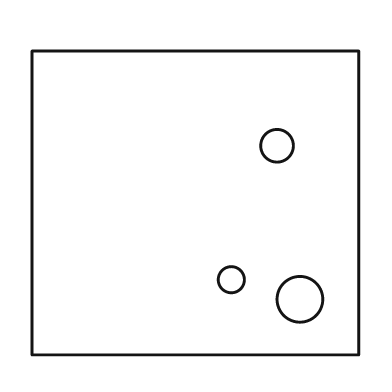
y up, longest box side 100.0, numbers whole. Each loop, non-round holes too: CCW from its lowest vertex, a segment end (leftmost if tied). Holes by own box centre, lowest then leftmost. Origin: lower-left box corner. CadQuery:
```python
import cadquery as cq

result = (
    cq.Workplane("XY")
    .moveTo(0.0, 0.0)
    .lineTo(100.0, 0.0)
    .lineTo(100.0, 93.0)
    .lineTo(0.0, 93.0)
    .close()
    .moveTo(82.0, 17.0)
    .circle(7.0)
    .moveTo(61.0, 23.0)
    .circle(4.0)
    .moveTo(75.0, 64.0)
    .circle(5.0)
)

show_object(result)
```